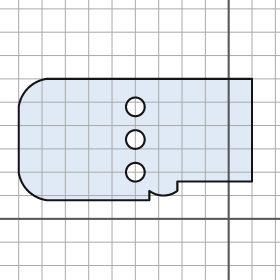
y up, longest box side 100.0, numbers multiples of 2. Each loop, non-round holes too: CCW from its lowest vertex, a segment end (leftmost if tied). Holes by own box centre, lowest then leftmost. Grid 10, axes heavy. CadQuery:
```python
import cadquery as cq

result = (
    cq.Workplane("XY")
    .moveTo(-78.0, 8.0)
    .lineTo(-34.0, 8.0)
    .lineTo(-34.0, 12.0)
    .threePointArc((-28.0, 10.0), (-22.0, 12.0))
    .lineTo(-22.0, 16.0)
    .lineTo(10.0, 16.0)
    .lineTo(10.0, 60.0)
    .lineTo(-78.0, 60.0)
    .threePointArc((-86.0, 56.0), (-90.0, 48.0))
    .lineTo(-90.0, 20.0)
    .threePointArc((-86.0, 12.0), (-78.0, 8.0))
    .close()
    .moveTo(-40.0, 20.0)
    .circle(4.0)
    .moveTo(-40.0, 34.0)
    .circle(4.0)
    .moveTo(-40.0, 48.0)
    .circle(4.0)
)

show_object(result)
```